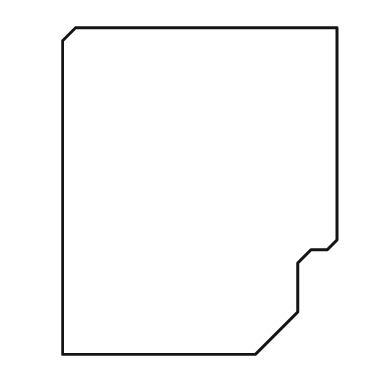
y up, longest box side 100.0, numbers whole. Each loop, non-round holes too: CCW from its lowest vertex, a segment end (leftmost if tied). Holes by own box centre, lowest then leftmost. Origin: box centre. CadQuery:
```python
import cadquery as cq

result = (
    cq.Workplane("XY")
    .moveTo(-42.0, -50.0)
    .lineTo(17.0, -50.0)
    .lineTo(30.0, -37.0)
    .lineTo(30.0, -22.0)
    .lineTo(34.0, -18.0)
    .lineTo(39.0, -18.0)
    .lineTo(42.0, -15.0)
    .lineTo(42.0, 50.0)
    .lineTo(-38.0, 50.0)
    .lineTo(-42.0, 46.0)
    .close()
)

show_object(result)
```